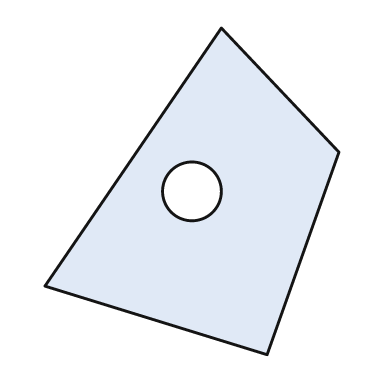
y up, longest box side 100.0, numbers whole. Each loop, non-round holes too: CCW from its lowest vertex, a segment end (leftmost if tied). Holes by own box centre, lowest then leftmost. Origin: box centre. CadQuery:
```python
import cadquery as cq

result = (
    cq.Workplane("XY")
    .moveTo(23.0, -50.0)
    .lineTo(45.0, 12.0)
    .lineTo(9.0, 50.0)
    .lineTo(-45.0, -29.0)
    .close()
    .moveTo(0.0, 0.0)
    .circle(9.0)
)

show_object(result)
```